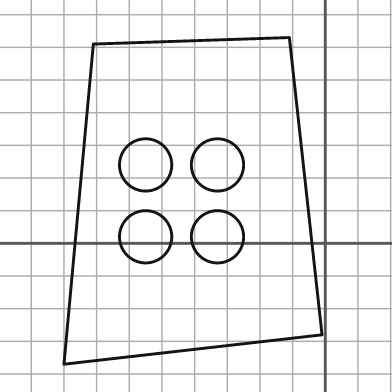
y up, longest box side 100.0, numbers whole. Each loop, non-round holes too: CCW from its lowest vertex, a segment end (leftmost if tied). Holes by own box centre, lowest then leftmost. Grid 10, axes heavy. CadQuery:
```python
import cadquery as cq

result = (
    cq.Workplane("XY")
    .moveTo(-80.0, -37.0)
    .lineTo(-1.0, -28.0)
    .lineTo(-11.0, 63.0)
    .lineTo(-71.0, 61.0)
    .close()
    .moveTo(-55.0, 2.0)
    .circle(8.0)
    .moveTo(-33.0, 2.0)
    .circle(8.0)
    .moveTo(-55.0, 24.0)
    .circle(8.0)
    .moveTo(-33.0, 24.0)
    .circle(8.0)
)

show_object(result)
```